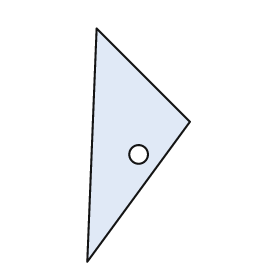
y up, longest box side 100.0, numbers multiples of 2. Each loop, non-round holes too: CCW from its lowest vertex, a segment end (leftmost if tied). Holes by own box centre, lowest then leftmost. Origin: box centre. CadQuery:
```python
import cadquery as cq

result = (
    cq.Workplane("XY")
    .moveTo(-22.0, -50.0)
    .lineTo(22.0, 10.0)
    .lineTo(-18.0, 50.0)
    .close()
    .moveTo(0.0, -4.0)
    .circle(4.0)
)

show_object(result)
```